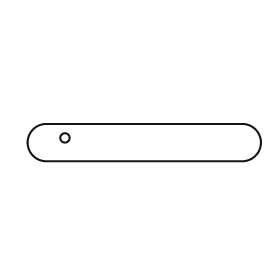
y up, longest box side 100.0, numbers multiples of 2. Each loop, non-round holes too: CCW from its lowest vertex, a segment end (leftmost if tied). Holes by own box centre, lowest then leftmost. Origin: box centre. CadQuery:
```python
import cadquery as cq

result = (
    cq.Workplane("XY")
    .moveTo(-42.0, -8.0)
    .lineTo(42.0, -8.0)
    .threePointArc((50.0, 0.0), (42.0, 8.0))
    .lineTo(-42.0, 8.0)
    .threePointArc((-50.0, 0.0), (-42.0, -8.0))
    .close()
    .moveTo(-34.0, 2.0)
    .circle(2.0)
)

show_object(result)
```